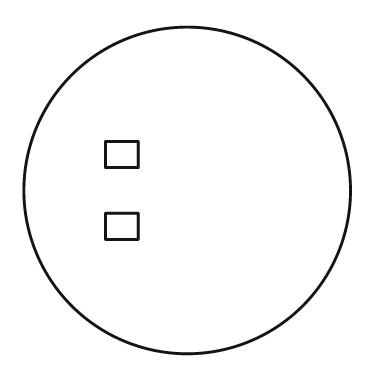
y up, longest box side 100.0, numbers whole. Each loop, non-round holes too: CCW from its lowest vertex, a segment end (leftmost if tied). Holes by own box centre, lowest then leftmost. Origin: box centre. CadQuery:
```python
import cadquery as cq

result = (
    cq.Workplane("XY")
    .moveTo(0.0, 0.0)
    .circle(50.0)
    .moveTo(-25.0, -15.0)
    .lineTo(-15.0, -15.0)
    .lineTo(-15.0, -7.0)
    .lineTo(-25.0, -7.0)
    .close()
    .moveTo(-25.0, 7.0)
    .lineTo(-15.0, 7.0)
    .lineTo(-15.0, 15.0)
    .lineTo(-25.0, 15.0)
    .close()
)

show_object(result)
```